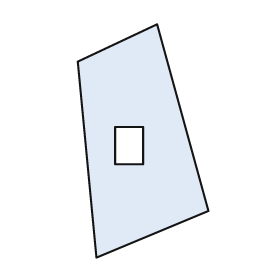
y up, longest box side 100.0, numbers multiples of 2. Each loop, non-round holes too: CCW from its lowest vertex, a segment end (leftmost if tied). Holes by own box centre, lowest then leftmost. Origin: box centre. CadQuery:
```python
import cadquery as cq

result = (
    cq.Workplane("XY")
    .moveTo(-20.0, -50.0)
    .lineTo(28.0, -30.0)
    .lineTo(6.0, 50.0)
    .lineTo(-28.0, 34.0)
    .close()
    .moveTo(-12.0, -10.0)
    .lineTo(0.0, -10.0)
    .lineTo(0.0, 6.0)
    .lineTo(-12.0, 6.0)
    .close()
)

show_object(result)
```